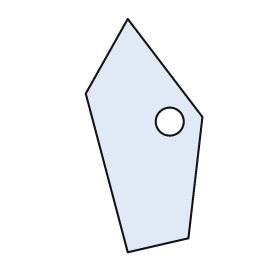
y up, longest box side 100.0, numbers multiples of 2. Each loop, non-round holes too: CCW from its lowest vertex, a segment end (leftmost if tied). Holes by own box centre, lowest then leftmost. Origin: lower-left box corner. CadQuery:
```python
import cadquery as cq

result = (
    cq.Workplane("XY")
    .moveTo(18.0, 0.0)
    .lineTo(44.0, 6.0)
    .lineTo(50.0, 58.0)
    .lineTo(18.0, 100.0)
    .lineTo(0.0, 68.0)
    .close()
    .moveTo(36.0, 56.0)
    .circle(6.0)
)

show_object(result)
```